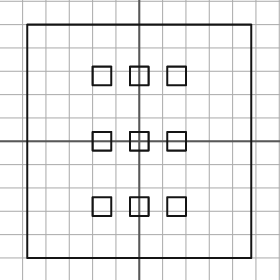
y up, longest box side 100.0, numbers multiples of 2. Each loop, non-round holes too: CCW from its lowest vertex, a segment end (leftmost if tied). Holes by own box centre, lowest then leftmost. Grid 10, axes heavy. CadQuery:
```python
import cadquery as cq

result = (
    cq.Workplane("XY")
    .moveTo(-48.0, -50.0)
    .lineTo(48.0, -50.0)
    .lineTo(48.0, 50.0)
    .lineTo(-48.0, 50.0)
    .close()
    .moveTo(-20.0, -32.0)
    .lineTo(-12.0, -32.0)
    .lineTo(-12.0, -24.0)
    .lineTo(-20.0, -24.0)
    .close()
    .moveTo(-4.0, -32.0)
    .lineTo(4.0, -32.0)
    .lineTo(4.0, -24.0)
    .lineTo(-4.0, -24.0)
    .close()
    .moveTo(12.0, -32.0)
    .lineTo(20.0, -32.0)
    .lineTo(20.0, -24.0)
    .lineTo(12.0, -24.0)
    .close()
    .moveTo(-20.0, -4.0)
    .lineTo(-12.0, -4.0)
    .lineTo(-12.0, 4.0)
    .lineTo(-20.0, 4.0)
    .close()
    .moveTo(-4.0, -4.0)
    .lineTo(4.0, -4.0)
    .lineTo(4.0, 4.0)
    .lineTo(-4.0, 4.0)
    .close()
    .moveTo(12.0, -4.0)
    .lineTo(20.0, -4.0)
    .lineTo(20.0, 4.0)
    .lineTo(12.0, 4.0)
    .close()
    .moveTo(-20.0, 24.0)
    .lineTo(-12.0, 24.0)
    .lineTo(-12.0, 32.0)
    .lineTo(-20.0, 32.0)
    .close()
    .moveTo(-4.0, 24.0)
    .lineTo(4.0, 24.0)
    .lineTo(4.0, 32.0)
    .lineTo(-4.0, 32.0)
    .close()
    .moveTo(12.0, 24.0)
    .lineTo(20.0, 24.0)
    .lineTo(20.0, 32.0)
    .lineTo(12.0, 32.0)
    .close()
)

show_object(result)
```